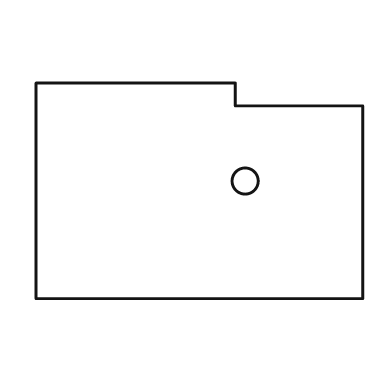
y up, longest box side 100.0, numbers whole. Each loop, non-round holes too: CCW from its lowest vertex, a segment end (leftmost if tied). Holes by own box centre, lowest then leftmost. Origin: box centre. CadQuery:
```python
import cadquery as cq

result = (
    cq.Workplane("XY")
    .moveTo(-50.0, -33.0)
    .lineTo(50.0, -33.0)
    .lineTo(50.0, 26.0)
    .lineTo(11.0, 26.0)
    .lineTo(11.0, 33.0)
    .lineTo(-50.0, 33.0)
    .close()
    .moveTo(14.0, 3.0)
    .circle(4.0)
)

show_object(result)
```